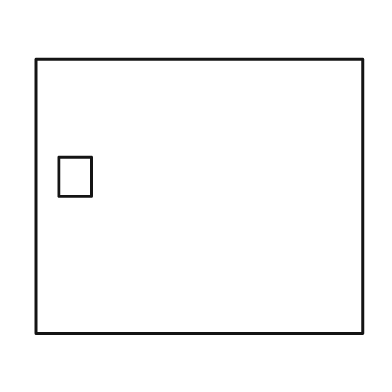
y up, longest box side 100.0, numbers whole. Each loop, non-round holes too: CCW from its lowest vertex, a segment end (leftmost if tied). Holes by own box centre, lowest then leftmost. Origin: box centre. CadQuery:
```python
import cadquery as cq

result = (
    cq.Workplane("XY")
    .moveTo(-50.0, -42.0)
    .lineTo(50.0, -42.0)
    .lineTo(50.0, 42.0)
    .lineTo(-50.0, 42.0)
    .close()
    .moveTo(-43.0, 0.0)
    .lineTo(-33.0, 0.0)
    .lineTo(-33.0, 12.0)
    .lineTo(-43.0, 12.0)
    .close()
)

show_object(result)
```